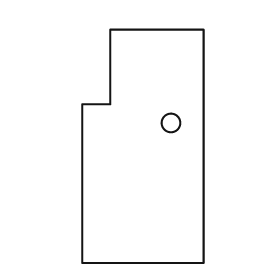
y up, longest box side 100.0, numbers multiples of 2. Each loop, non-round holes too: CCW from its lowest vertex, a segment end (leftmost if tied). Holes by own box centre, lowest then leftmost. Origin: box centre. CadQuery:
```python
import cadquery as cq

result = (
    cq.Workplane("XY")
    .moveTo(-26.0, -50.0)
    .lineTo(26.0, -50.0)
    .lineTo(26.0, 50.0)
    .lineTo(-14.0, 50.0)
    .lineTo(-14.0, 18.0)
    .lineTo(-26.0, 18.0)
    .close()
    .moveTo(12.0, 10.0)
    .circle(4.0)
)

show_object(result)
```